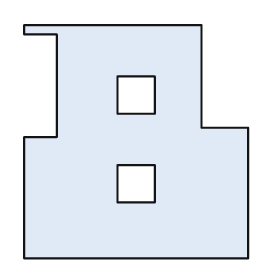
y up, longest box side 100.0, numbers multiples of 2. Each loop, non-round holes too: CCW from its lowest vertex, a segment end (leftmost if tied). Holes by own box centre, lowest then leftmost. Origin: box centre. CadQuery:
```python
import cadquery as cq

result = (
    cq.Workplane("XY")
    .moveTo(-48.0, -50.0)
    .lineTo(48.0, -50.0)
    .lineTo(48.0, 6.0)
    .lineTo(28.0, 6.0)
    .lineTo(28.0, 50.0)
    .lineTo(-48.0, 50.0)
    .lineTo(-48.0, 46.0)
    .lineTo(-34.0, 46.0)
    .lineTo(-34.0, 2.0)
    .lineTo(-48.0, 2.0)
    .close()
    .moveTo(-8.0, -26.0)
    .lineTo(8.0, -26.0)
    .lineTo(8.0, -10.0)
    .lineTo(-8.0, -10.0)
    .close()
    .moveTo(-8.0, 12.0)
    .lineTo(8.0, 12.0)
    .lineTo(8.0, 28.0)
    .lineTo(-8.0, 28.0)
    .close()
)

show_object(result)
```